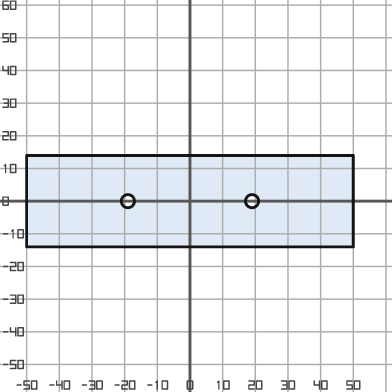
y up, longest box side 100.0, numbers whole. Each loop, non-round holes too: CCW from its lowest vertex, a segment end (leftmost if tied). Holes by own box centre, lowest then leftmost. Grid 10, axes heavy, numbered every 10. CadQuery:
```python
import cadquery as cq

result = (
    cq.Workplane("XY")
    .moveTo(-50.0, -14.0)
    .lineTo(50.0, -14.0)
    .lineTo(50.0, 14.0)
    .lineTo(-50.0, 14.0)
    .close()
    .moveTo(-19.0, 0.0)
    .circle(2.0)
    .moveTo(19.0, 0.0)
    .circle(2.0)
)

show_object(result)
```